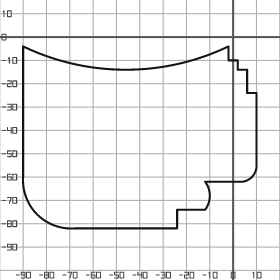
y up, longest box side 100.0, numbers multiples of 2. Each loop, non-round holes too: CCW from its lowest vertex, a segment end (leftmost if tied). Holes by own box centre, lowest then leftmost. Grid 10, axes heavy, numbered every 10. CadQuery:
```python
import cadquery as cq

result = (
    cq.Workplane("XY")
    .moveTo(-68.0, -82.0)
    .lineTo(-24.0, -82.0)
    .lineTo(-24.0, -74.0)
    .lineTo(-12.0, -74.0)
    .threePointArc((-10.0, -68.0), (-12.0, -62.0))
    .lineTo(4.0, -62.0)
    .threePointArc((8.0, -60.0), (10.0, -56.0))
    .lineTo(10.0, -24.0)
    .lineTo(6.0, -24.0)
    .lineTo(6.0, -14.0)
    .lineTo(2.0, -14.0)
    .lineTo(2.0, -10.0)
    .lineTo(-2.0, -10.0)
    .lineTo(-2.0, -4.0)
    .threePointArc((-46.0, -14.0), (-90.0, -4.0))
    .lineTo(-90.0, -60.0)
    .threePointArc((-84.0, -76.0), (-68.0, -82.0))
    .close()
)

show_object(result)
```